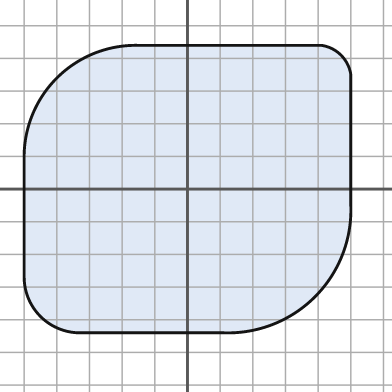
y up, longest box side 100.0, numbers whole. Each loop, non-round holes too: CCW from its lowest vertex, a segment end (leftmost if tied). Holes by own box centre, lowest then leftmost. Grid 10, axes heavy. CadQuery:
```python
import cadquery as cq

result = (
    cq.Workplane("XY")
    .moveTo(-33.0, -44.0)
    .lineTo(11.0, -44.0)
    .threePointArc((39.0, -33.0), (50.0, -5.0))
    .lineTo(50.0, 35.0)
    .threePointArc((47.0, 41.0), (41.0, 44.0))
    .lineTo(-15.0, 44.0)
    .threePointArc((-40.0, 34.0), (-50.0, 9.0))
    .lineTo(-50.0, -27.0)
    .threePointArc((-45.0, -39.0), (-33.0, -44.0))
    .close()
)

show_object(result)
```